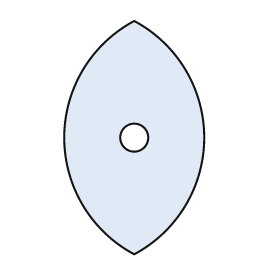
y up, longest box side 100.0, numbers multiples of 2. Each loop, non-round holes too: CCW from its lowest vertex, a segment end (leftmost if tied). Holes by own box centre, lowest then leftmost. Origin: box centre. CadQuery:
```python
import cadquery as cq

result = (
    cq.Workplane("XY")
    .moveTo(0.0, -50.0)
    .threePointArc((30.0, 0.0), (0.0, 50.0))
    .threePointArc((-30.0, 0.0), (0.0, -50.0))
    .close()
    .moveTo(0.0, 0.0)
    .circle(6.0)
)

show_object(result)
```